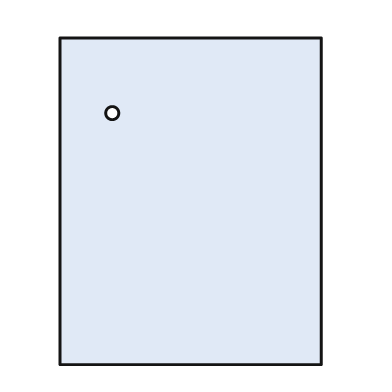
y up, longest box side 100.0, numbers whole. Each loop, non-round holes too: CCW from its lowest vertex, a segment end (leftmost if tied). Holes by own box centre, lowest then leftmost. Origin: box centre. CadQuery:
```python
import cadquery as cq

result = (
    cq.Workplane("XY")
    .moveTo(-40.0, -50.0)
    .lineTo(40.0, -50.0)
    .lineTo(40.0, 50.0)
    .lineTo(-40.0, 50.0)
    .close()
    .moveTo(-24.0, 27.0)
    .circle(2.0)
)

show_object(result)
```